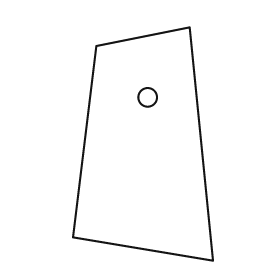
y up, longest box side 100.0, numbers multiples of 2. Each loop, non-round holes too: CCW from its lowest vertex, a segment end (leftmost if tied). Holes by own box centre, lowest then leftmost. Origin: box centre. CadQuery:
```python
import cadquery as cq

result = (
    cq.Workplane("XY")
    .moveTo(30.0, -50.0)
    .lineTo(20.0, 50.0)
    .lineTo(-20.0, 42.0)
    .lineTo(-30.0, -40.0)
    .close()
    .moveTo(2.0, 20.0)
    .circle(4.0)
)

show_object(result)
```